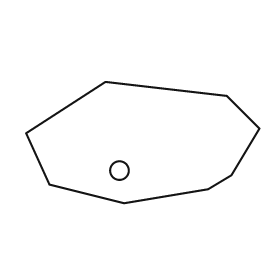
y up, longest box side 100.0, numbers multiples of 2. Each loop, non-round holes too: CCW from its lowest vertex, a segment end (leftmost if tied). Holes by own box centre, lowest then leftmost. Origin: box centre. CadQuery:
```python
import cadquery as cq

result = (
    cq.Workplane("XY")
    .moveTo(-8.0, -26.0)
    .lineTo(28.0, -20.0)
    .lineTo(38.0, -14.0)
    .lineTo(50.0, 6.0)
    .lineTo(36.0, 20.0)
    .lineTo(-16.0, 26.0)
    .lineTo(-50.0, 4.0)
    .lineTo(-40.0, -18.0)
    .close()
    .moveTo(-10.0, -12.0)
    .circle(4.0)
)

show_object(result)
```